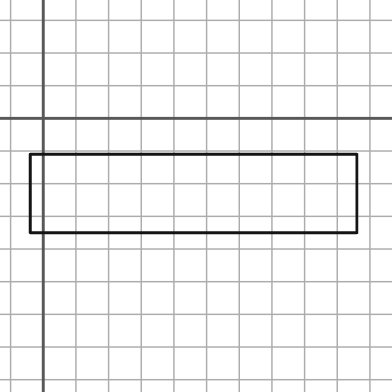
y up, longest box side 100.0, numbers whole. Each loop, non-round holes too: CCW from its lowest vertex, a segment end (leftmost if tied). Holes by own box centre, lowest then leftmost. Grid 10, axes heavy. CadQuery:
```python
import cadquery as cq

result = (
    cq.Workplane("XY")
    .moveTo(-4.0, -35.0)
    .lineTo(96.0, -35.0)
    .lineTo(96.0, -11.0)
    .lineTo(-4.0, -11.0)
    .close()
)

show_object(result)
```